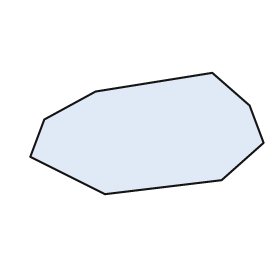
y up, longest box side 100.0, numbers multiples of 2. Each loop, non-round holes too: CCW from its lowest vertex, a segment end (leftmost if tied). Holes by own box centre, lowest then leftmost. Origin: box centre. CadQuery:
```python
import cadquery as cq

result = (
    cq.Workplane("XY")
    .moveTo(-18.0, -26.0)
    .lineTo(32.0, -20.0)
    .lineTo(50.0, -4.0)
    .lineTo(44.0, 12.0)
    .lineTo(28.0, 26.0)
    .lineTo(-22.0, 18.0)
    .lineTo(-44.0, 6.0)
    .lineTo(-50.0, -10.0)
    .close()
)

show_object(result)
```